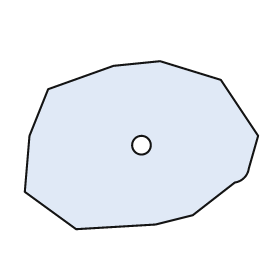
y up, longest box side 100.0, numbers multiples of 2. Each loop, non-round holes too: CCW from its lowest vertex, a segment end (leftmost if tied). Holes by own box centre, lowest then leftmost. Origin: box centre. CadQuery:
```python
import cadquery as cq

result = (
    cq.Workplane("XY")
    .moveTo(-28.0, -36.0)
    .lineTo(6.0, -34.0)
    .lineTo(22.0, -30.0)
    .lineTo(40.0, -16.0)
    .threePointArc((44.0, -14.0), (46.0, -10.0))
    .lineTo(50.0, 4.0)
    .lineTo(34.0, 28.0)
    .lineTo(8.0, 36.0)
    .lineTo(-12.0, 34.0)
    .lineTo(-40.0, 24.0)
    .lineTo(-48.0, 4.0)
    .lineTo(-50.0, -20.0)
    .close()
    .moveTo(0.0, 0.0)
    .circle(4.0)
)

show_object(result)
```